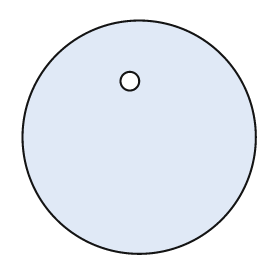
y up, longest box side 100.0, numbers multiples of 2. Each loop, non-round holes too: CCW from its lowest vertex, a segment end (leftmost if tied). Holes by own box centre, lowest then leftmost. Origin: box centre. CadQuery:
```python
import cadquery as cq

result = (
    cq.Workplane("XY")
    .moveTo(0.0, 0.0)
    .circle(50.0)
    .moveTo(-4.0, 24.0)
    .circle(4.0)
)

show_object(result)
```